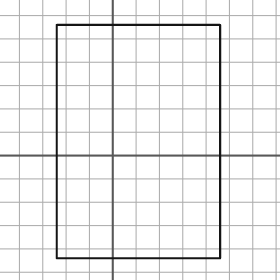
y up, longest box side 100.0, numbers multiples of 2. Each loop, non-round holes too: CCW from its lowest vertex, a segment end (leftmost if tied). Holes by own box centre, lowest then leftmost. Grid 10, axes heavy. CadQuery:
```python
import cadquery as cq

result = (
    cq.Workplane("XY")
    .moveTo(-24.0, -44.0)
    .lineTo(46.0, -44.0)
    .lineTo(46.0, 56.0)
    .lineTo(-24.0, 56.0)
    .close()
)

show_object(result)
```